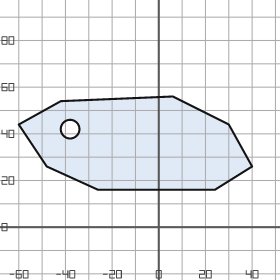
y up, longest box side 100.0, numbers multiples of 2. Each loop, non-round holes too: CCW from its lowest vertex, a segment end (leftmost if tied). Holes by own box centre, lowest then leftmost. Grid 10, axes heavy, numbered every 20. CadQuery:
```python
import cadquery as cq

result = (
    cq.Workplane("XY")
    .moveTo(-26.0, 16.0)
    .lineTo(24.0, 16.0)
    .lineTo(40.0, 26.0)
    .lineTo(30.0, 44.0)
    .lineTo(6.0, 56.0)
    .lineTo(-42.0, 54.0)
    .lineTo(-60.0, 44.0)
    .lineTo(-48.0, 26.0)
    .close()
    .moveTo(-38.0, 42.0)
    .circle(4.0)
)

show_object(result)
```